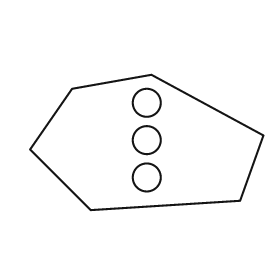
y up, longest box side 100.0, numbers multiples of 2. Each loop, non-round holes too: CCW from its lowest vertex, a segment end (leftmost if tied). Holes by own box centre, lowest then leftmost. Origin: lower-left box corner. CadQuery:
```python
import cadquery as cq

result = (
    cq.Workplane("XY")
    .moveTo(26.0, 0.0)
    .lineTo(90.0, 4.0)
    .lineTo(100.0, 32.0)
    .lineTo(52.0, 58.0)
    .lineTo(18.0, 52.0)
    .lineTo(0.0, 26.0)
    .close()
    .moveTo(50.0, 14.0)
    .circle(6.0)
    .moveTo(50.0, 30.0)
    .circle(6.0)
    .moveTo(50.0, 46.0)
    .circle(6.0)
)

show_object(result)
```